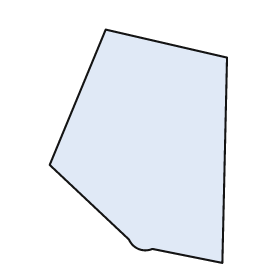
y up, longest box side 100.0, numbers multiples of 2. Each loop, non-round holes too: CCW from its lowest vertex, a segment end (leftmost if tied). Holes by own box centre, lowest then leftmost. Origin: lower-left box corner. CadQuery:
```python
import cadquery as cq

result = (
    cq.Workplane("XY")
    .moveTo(74.0, 0.0)
    .lineTo(76.0, 88.0)
    .lineTo(24.0, 100.0)
    .lineTo(0.0, 42.0)
    .lineTo(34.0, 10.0)
    .threePointArc((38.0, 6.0), (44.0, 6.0))
    .close()
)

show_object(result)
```